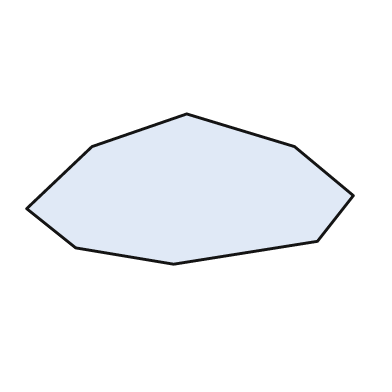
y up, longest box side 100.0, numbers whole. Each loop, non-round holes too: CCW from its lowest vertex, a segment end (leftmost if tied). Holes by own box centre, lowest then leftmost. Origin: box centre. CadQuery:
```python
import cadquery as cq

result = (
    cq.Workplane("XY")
    .moveTo(-5.0, -23.0)
    .lineTo(39.0, -16.0)
    .lineTo(50.0, -2.0)
    .lineTo(32.0, 13.0)
    .lineTo(-1.0, 23.0)
    .lineTo(-30.0, 13.0)
    .lineTo(-50.0, -6.0)
    .lineTo(-35.0, -18.0)
    .close()
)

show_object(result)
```